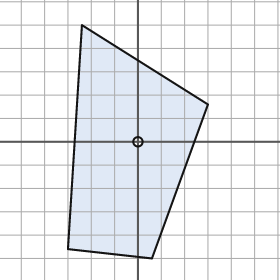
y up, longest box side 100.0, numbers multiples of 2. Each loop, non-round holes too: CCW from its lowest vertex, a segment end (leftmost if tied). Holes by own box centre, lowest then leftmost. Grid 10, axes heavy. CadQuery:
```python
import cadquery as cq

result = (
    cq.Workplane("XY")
    .moveTo(6.0, -50.0)
    .lineTo(30.0, 16.0)
    .lineTo(-24.0, 50.0)
    .lineTo(-30.0, -46.0)
    .close()
    .moveTo(0.0, 0.0)
    .circle(2.0)
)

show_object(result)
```